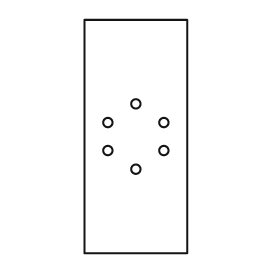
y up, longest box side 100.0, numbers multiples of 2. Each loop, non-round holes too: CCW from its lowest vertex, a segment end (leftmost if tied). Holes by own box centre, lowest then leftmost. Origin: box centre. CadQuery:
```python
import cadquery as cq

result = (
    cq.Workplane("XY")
    .moveTo(-22.0, -50.0)
    .lineTo(22.0, -50.0)
    .lineTo(22.0, 50.0)
    .lineTo(-22.0, 50.0)
    .close()
    .moveTo(0.0, -14.0)
    .circle(2.0)
    .moveTo(-12.0, -6.0)
    .circle(2.0)
    .moveTo(12.0, -6.0)
    .circle(2.0)
    .moveTo(-12.0, 6.0)
    .circle(2.0)
    .moveTo(12.0, 6.0)
    .circle(2.0)
    .moveTo(0.0, 14.0)
    .circle(2.0)
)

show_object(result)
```